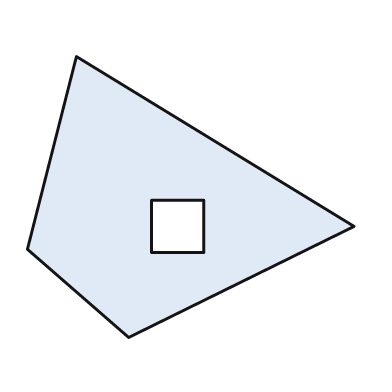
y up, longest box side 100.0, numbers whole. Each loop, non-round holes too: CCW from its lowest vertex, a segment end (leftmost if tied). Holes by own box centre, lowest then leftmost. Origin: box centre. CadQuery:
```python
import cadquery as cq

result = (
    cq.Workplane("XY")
    .moveTo(-19.0, -43.0)
    .lineTo(50.0, -9.0)
    .lineTo(-35.0, 43.0)
    .lineTo(-50.0, -16.0)
    .close()
    .moveTo(-12.0, -17.0)
    .lineTo(4.0, -17.0)
    .lineTo(4.0, -1.0)
    .lineTo(-12.0, -1.0)
    .close()
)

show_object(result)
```